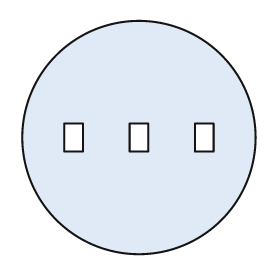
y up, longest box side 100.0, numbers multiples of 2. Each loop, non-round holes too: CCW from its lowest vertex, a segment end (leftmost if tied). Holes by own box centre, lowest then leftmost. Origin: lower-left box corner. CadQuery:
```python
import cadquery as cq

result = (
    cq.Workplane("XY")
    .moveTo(50.0, 50.0)
    .circle(50.0)
    .moveTo(18.0, 44.0)
    .lineTo(26.0, 44.0)
    .lineTo(26.0, 56.0)
    .lineTo(18.0, 56.0)
    .close()
    .moveTo(46.0, 44.0)
    .lineTo(54.0, 44.0)
    .lineTo(54.0, 56.0)
    .lineTo(46.0, 56.0)
    .close()
    .moveTo(74.0, 44.0)
    .lineTo(82.0, 44.0)
    .lineTo(82.0, 56.0)
    .lineTo(74.0, 56.0)
    .close()
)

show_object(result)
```